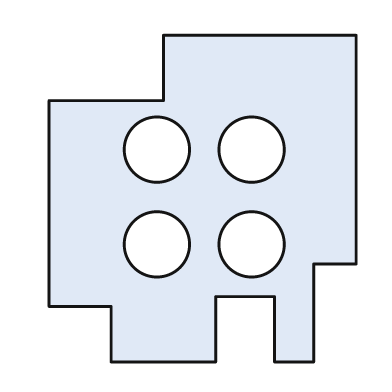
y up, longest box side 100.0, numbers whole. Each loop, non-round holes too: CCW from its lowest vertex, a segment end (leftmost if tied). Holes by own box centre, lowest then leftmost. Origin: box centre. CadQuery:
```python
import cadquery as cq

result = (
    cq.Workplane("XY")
    .moveTo(-28.0, -50.0)
    .lineTo(4.0, -50.0)
    .lineTo(4.0, -30.0)
    .lineTo(22.0, -30.0)
    .lineTo(22.0, -50.0)
    .lineTo(34.0, -50.0)
    .lineTo(34.0, -20.0)
    .lineTo(47.0, -20.0)
    .lineTo(47.0, 50.0)
    .lineTo(-12.0, 50.0)
    .lineTo(-12.0, 30.0)
    .lineTo(-47.0, 30.0)
    .lineTo(-47.0, -33.0)
    .lineTo(-28.0, -33.0)
    .close()
    .moveTo(-14.0, -14.0)
    .circle(10.0)
    .moveTo(15.0, -14.0)
    .circle(10.0)
    .moveTo(-14.0, 15.0)
    .circle(10.0)
    .moveTo(15.0, 15.0)
    .circle(10.0)
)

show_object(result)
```